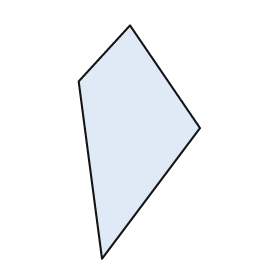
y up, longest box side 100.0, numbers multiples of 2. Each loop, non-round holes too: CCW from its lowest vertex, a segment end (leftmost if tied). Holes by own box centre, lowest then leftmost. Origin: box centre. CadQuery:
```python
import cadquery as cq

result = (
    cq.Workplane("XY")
    .moveTo(-16.0, -50.0)
    .lineTo(26.0, 6.0)
    .lineTo(-4.0, 50.0)
    .lineTo(-26.0, 26.0)
    .close()
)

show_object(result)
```